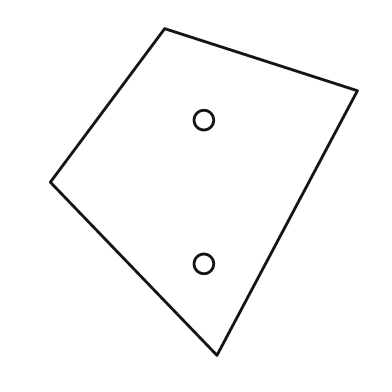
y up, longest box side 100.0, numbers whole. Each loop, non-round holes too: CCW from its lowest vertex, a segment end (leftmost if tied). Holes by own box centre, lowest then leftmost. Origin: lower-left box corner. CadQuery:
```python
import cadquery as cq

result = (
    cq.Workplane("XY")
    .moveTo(51.0, 0.0)
    .lineTo(94.0, 81.0)
    .lineTo(35.0, 100.0)
    .lineTo(0.0, 53.0)
    .close()
    .moveTo(47.0, 28.0)
    .circle(3.0)
    .moveTo(47.0, 72.0)
    .circle(3.0)
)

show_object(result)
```